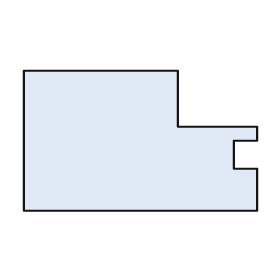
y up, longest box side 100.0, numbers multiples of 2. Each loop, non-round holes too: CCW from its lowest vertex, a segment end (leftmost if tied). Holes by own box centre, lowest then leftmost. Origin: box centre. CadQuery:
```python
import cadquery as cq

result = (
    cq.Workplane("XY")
    .moveTo(-50.0, -30.0)
    .lineTo(50.0, -30.0)
    .lineTo(50.0, -12.0)
    .lineTo(40.0, -12.0)
    .lineTo(40.0, 0.0)
    .lineTo(50.0, 0.0)
    .lineTo(50.0, 6.0)
    .lineTo(16.0, 6.0)
    .lineTo(16.0, 30.0)
    .lineTo(-50.0, 30.0)
    .close()
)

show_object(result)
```